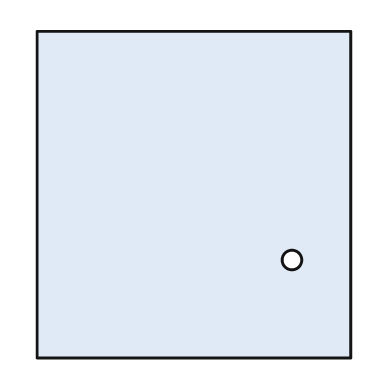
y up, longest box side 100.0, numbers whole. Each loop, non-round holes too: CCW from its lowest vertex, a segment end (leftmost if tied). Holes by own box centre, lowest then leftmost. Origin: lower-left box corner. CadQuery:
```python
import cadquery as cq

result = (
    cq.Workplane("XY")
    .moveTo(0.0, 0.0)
    .lineTo(96.0, 0.0)
    .lineTo(96.0, 100.0)
    .lineTo(0.0, 100.0)
    .close()
    .moveTo(78.0, 30.0)
    .circle(3.0)
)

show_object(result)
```